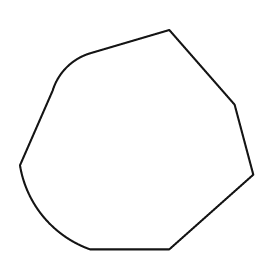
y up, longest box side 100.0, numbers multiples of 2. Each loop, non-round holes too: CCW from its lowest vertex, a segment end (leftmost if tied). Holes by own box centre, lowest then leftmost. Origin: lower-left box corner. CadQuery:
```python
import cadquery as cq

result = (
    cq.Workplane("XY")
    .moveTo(30.0, 0.0)
    .lineTo(64.0, 0.0)
    .lineTo(100.0, 32.0)
    .lineTo(92.0, 62.0)
    .lineTo(64.0, 94.0)
    .lineTo(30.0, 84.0)
    .threePointArc((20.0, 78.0), (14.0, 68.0))
    .lineTo(0.0, 36.0)
    .threePointArc((10.0, 14.0), (30.0, 0.0))
    .close()
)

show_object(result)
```